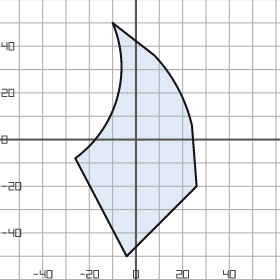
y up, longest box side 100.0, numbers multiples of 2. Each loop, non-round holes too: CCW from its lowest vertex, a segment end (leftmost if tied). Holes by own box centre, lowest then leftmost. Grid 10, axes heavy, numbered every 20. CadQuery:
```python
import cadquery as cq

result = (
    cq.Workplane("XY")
    .moveTo(-4.0, -50.0)
    .lineTo(26.0, -20.0)
    .lineTo(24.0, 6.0)
    .threePointArc((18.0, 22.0), (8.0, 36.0))
    .lineTo(-10.0, 50.0)
    .threePointArc((-8.0, 18.0), (-26.0, -8.0))
    .close()
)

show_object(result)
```